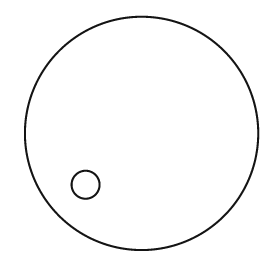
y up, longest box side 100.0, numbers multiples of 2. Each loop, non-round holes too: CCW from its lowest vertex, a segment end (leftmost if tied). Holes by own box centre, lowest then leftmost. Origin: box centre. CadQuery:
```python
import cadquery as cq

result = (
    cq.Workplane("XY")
    .moveTo(0.0, 0.0)
    .circle(50.0)
    .moveTo(-24.0, -22.0)
    .circle(6.0)
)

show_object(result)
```